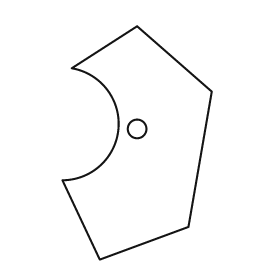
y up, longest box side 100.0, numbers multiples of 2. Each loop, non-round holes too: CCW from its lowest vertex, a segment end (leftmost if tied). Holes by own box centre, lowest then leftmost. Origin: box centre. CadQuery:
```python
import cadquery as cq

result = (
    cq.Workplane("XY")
    .moveTo(-16.0, -50.0)
    .lineTo(22.0, -36.0)
    .lineTo(32.0, 22.0)
    .lineTo(0.0, 50.0)
    .lineTo(-28.0, 32.0)
    .threePointArc((-8.0, 6.0), (-32.0, -16.0))
    .close()
    .moveTo(0.0, 6.0)
    .circle(4.0)
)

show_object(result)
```